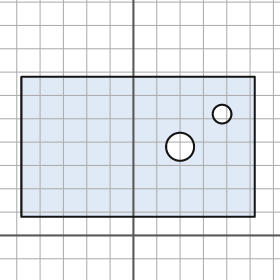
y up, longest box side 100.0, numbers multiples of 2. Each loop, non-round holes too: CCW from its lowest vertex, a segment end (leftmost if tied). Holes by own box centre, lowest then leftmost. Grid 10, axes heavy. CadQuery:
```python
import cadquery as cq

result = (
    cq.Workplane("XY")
    .moveTo(-48.0, 8.0)
    .lineTo(52.0, 8.0)
    .lineTo(52.0, 68.0)
    .lineTo(-48.0, 68.0)
    .close()
    .moveTo(20.0, 38.0)
    .circle(6.0)
    .moveTo(38.0, 52.0)
    .circle(4.0)
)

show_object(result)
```